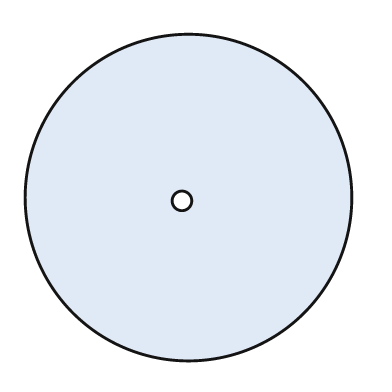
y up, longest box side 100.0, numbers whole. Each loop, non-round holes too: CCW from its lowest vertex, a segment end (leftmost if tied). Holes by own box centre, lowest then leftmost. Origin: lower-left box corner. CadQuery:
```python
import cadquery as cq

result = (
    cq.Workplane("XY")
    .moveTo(50.0, 50.0)
    .circle(50.0)
    .moveTo(48.0, 49.0)
    .circle(3.0)
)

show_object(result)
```